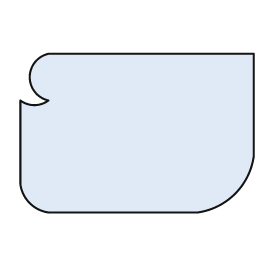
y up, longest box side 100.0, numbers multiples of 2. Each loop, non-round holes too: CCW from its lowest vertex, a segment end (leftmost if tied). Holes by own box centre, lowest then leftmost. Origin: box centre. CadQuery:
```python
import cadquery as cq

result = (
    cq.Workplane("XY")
    .moveTo(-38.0, -34.0)
    .lineTo(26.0, -34.0)
    .threePointArc((42.0, -26.0), (50.0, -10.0))
    .lineTo(50.0, 34.0)
    .lineTo(-38.0, 34.0)
    .threePointArc((-46.0, 24.0), (-38.0, 14.0))
    .threePointArc((-44.0, 12.0), (-50.0, 14.0))
    .lineTo(-50.0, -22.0)
    .threePointArc((-46.0, -30.0), (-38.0, -34.0))
    .close()
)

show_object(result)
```